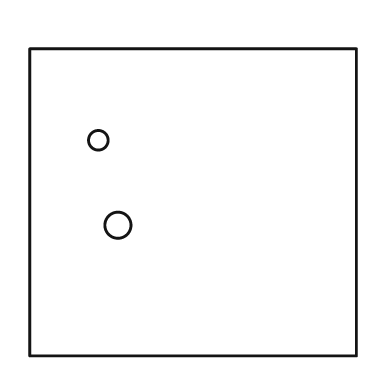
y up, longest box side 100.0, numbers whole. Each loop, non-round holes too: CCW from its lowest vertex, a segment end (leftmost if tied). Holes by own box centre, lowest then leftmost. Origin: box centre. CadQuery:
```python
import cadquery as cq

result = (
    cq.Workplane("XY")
    .moveTo(-50.0, -47.0)
    .lineTo(50.0, -47.0)
    .lineTo(50.0, 47.0)
    .lineTo(-50.0, 47.0)
    .close()
    .moveTo(-23.0, -7.0)
    .circle(4.0)
    .moveTo(-29.0, 19.0)
    .circle(3.0)
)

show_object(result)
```